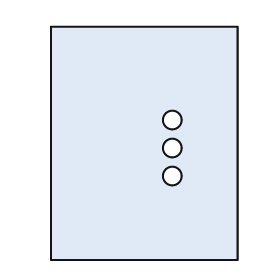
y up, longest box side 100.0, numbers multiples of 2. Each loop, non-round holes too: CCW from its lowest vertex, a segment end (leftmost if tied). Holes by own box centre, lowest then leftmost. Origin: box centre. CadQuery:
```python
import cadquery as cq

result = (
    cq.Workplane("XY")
    .moveTo(-40.0, -50.0)
    .lineTo(40.0, -50.0)
    .lineTo(40.0, 50.0)
    .lineTo(-40.0, 50.0)
    .close()
    .moveTo(12.0, -14.0)
    .circle(4.0)
    .moveTo(12.0, -2.0)
    .circle(4.0)
    .moveTo(12.0, 10.0)
    .circle(4.0)
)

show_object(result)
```